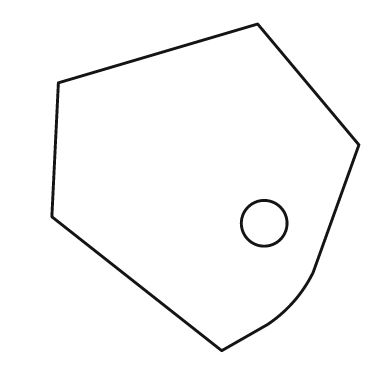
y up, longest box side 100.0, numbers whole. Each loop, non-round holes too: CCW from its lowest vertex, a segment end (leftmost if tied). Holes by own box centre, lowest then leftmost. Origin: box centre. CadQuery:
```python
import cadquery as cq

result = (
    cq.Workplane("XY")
    .moveTo(5.0, -50.0)
    .lineTo(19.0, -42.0)
    .threePointArc((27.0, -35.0), (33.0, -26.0))
    .lineTo(47.0, 13.0)
    .lineTo(16.0, 50.0)
    .lineTo(-45.0, 32.0)
    .lineTo(-47.0, -9.0)
    .close()
    .moveTo(18.0, -11.0)
    .circle(7.0)
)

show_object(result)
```